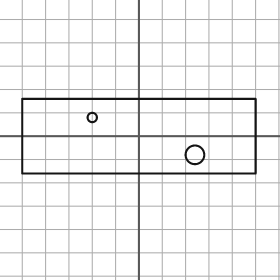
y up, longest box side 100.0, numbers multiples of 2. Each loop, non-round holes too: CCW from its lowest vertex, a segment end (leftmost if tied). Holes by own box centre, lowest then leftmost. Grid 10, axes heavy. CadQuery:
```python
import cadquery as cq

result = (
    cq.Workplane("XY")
    .moveTo(-50.0, -16.0)
    .lineTo(50.0, -16.0)
    .lineTo(50.0, 16.0)
    .lineTo(-50.0, 16.0)
    .close()
    .moveTo(24.0, -8.0)
    .circle(4.0)
    .moveTo(-20.0, 8.0)
    .circle(2.0)
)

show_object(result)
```